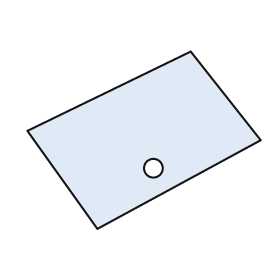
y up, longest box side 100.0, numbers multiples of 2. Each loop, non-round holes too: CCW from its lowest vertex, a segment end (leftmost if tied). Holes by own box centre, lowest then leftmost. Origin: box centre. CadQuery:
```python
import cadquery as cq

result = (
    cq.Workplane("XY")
    .moveTo(-20.0, -38.0)
    .lineTo(50.0, 0.0)
    .lineTo(20.0, 38.0)
    .lineTo(-50.0, 4.0)
    .close()
    .moveTo(4.0, -12.0)
    .circle(4.0)
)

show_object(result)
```